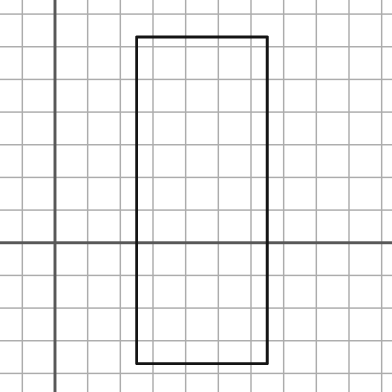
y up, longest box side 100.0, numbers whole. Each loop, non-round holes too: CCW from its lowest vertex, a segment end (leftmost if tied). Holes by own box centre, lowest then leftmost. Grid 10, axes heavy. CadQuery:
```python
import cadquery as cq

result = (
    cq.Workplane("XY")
    .moveTo(25.0, -37.0)
    .lineTo(65.0, -37.0)
    .lineTo(65.0, 63.0)
    .lineTo(25.0, 63.0)
    .close()
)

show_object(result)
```